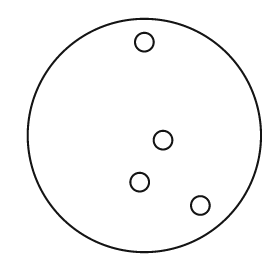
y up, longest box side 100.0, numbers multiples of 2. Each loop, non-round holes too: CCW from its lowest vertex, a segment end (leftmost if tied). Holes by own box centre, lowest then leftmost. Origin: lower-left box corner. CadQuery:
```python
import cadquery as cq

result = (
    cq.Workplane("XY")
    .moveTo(50.0, 50.0)
    .circle(50.0)
    .moveTo(74.0, 20.0)
    .circle(4.0)
    .moveTo(48.0, 30.0)
    .circle(4.0)
    .moveTo(58.0, 48.0)
    .circle(4.0)
    .moveTo(50.0, 90.0)
    .circle(4.0)
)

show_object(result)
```